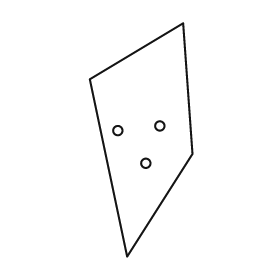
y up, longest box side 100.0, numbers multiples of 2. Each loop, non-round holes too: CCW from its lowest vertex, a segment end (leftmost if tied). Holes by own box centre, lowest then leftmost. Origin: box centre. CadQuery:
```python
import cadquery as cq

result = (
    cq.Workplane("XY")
    .moveTo(-6.0, -50.0)
    .lineTo(22.0, -6.0)
    .lineTo(18.0, 50.0)
    .lineTo(-22.0, 26.0)
    .close()
    .moveTo(2.0, -10.0)
    .circle(2.0)
    .moveTo(-10.0, 4.0)
    .circle(2.0)
    .moveTo(8.0, 6.0)
    .circle(2.0)
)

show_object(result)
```